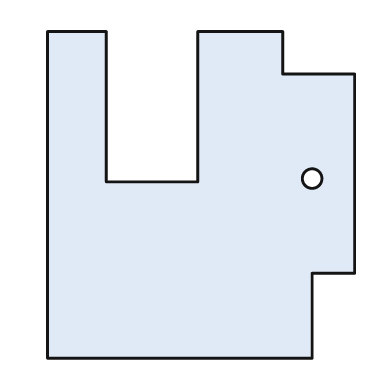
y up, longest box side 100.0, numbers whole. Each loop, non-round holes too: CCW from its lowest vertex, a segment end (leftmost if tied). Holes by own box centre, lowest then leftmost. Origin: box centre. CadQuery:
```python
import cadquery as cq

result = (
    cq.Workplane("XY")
    .moveTo(-47.0, -50.0)
    .lineTo(34.0, -50.0)
    .lineTo(34.0, -24.0)
    .lineTo(47.0, -24.0)
    .lineTo(47.0, 37.0)
    .lineTo(25.0, 37.0)
    .lineTo(25.0, 50.0)
    .lineTo(-1.0, 50.0)
    .lineTo(-1.0, 4.0)
    .lineTo(-29.0, 4.0)
    .lineTo(-29.0, 50.0)
    .lineTo(-47.0, 50.0)
    .close()
    .moveTo(34.0, 5.0)
    .circle(3.0)
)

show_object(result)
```